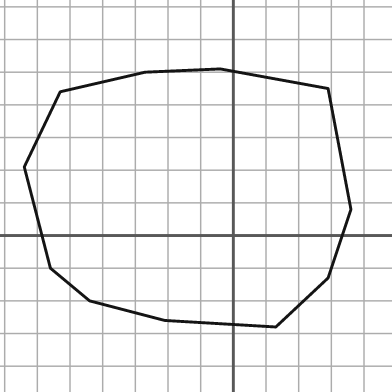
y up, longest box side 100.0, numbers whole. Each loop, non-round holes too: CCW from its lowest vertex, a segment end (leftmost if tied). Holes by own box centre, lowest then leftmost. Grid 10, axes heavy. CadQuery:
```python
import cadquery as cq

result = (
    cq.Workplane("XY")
    .moveTo(13.0, -28.0)
    .lineTo(29.0, -13.0)
    .lineTo(36.0, 8.0)
    .lineTo(29.0, 45.0)
    .lineTo(-4.0, 51.0)
    .lineTo(-27.0, 50.0)
    .lineTo(-53.0, 44.0)
    .lineTo(-64.0, 21.0)
    .lineTo(-56.0, -10.0)
    .lineTo(-44.0, -20.0)
    .lineTo(-21.0, -26.0)
    .close()
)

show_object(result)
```